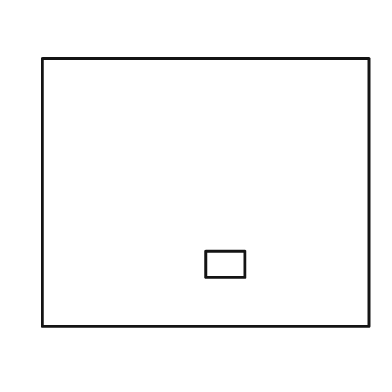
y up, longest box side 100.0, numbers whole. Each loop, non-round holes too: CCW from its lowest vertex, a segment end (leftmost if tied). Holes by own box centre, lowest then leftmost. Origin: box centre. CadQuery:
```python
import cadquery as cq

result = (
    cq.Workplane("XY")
    .moveTo(-50.0, -41.0)
    .lineTo(50.0, -41.0)
    .lineTo(50.0, 41.0)
    .lineTo(-50.0, 41.0)
    .close()
    .moveTo(0.0, -26.0)
    .lineTo(12.0, -26.0)
    .lineTo(12.0, -18.0)
    .lineTo(0.0, -18.0)
    .close()
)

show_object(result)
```